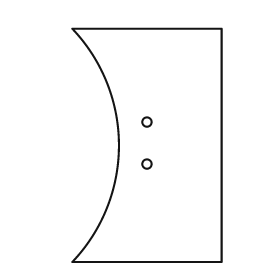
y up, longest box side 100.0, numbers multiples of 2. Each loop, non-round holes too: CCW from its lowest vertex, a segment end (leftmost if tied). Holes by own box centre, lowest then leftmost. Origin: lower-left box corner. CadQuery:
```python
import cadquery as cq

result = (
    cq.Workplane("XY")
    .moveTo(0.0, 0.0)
    .lineTo(64.0, 0.0)
    .lineTo(64.0, 100.0)
    .lineTo(0.0, 100.0)
    .threePointArc((20.0, 50.0), (0.0, 0.0))
    .close()
    .moveTo(32.0, 42.0)
    .circle(2.0)
    .moveTo(32.0, 60.0)
    .circle(2.0)
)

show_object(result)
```